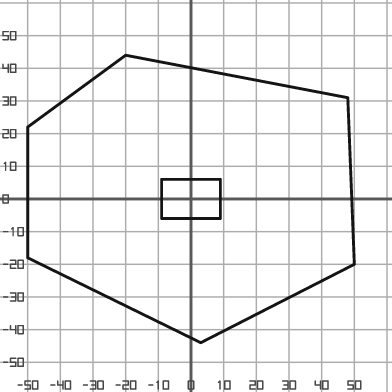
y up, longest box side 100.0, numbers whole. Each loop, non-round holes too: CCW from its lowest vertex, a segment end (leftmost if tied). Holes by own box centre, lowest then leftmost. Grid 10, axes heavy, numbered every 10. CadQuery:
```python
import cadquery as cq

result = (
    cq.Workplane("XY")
    .moveTo(3.0, -44.0)
    .lineTo(50.0, -20.0)
    .lineTo(48.0, 31.0)
    .lineTo(-20.0, 44.0)
    .lineTo(-50.0, 22.0)
    .lineTo(-50.0, -18.0)
    .close()
    .moveTo(-9.0, -6.0)
    .lineTo(9.0, -6.0)
    .lineTo(9.0, 6.0)
    .lineTo(-9.0, 6.0)
    .close()
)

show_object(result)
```